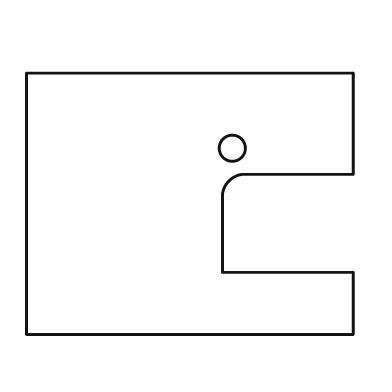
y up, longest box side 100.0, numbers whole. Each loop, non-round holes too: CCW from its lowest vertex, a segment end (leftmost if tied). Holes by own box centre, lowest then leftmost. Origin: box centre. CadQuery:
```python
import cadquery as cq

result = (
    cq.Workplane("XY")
    .moveTo(-50.0, -40.0)
    .lineTo(50.0, -40.0)
    .lineTo(50.0, -21.0)
    .lineTo(10.0, -21.0)
    .lineTo(10.0, 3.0)
    .threePointArc((12.0, 7.0), (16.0, 9.0))
    .lineTo(50.0, 9.0)
    .lineTo(50.0, 40.0)
    .lineTo(-50.0, 40.0)
    .close()
    .moveTo(13.0, 17.0)
    .circle(4.0)
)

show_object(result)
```